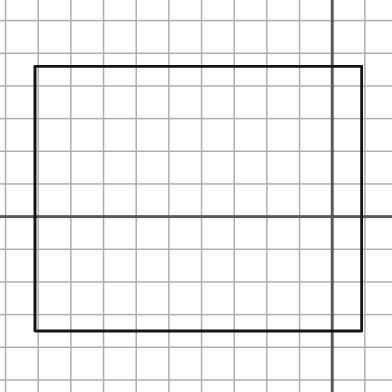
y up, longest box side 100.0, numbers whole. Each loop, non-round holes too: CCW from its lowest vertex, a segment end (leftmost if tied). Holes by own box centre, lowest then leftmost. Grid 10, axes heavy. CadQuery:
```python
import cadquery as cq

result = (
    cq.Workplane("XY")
    .moveTo(-91.0, -35.0)
    .lineTo(9.0, -35.0)
    .lineTo(9.0, 46.0)
    .lineTo(-91.0, 46.0)
    .close()
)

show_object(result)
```